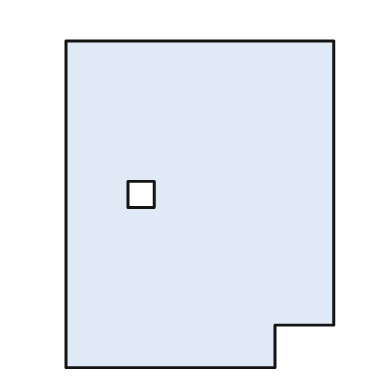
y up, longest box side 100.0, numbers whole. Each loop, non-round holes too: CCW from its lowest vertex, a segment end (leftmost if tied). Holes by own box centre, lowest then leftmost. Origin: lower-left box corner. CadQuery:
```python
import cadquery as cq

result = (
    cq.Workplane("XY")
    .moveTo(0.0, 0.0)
    .lineTo(64.0, 0.0)
    .lineTo(64.0, 13.0)
    .lineTo(82.0, 13.0)
    .lineTo(82.0, 100.0)
    .lineTo(0.0, 100.0)
    .close()
    .moveTo(19.0, 49.0)
    .lineTo(27.0, 49.0)
    .lineTo(27.0, 57.0)
    .lineTo(19.0, 57.0)
    .close()
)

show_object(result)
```